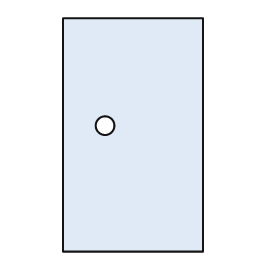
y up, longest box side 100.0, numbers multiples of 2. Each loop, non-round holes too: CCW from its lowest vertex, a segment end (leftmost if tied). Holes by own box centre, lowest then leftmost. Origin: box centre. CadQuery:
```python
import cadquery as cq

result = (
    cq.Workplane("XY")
    .moveTo(-30.0, -50.0)
    .lineTo(30.0, -50.0)
    .lineTo(30.0, 50.0)
    .lineTo(-30.0, 50.0)
    .close()
    .moveTo(-12.0, 4.0)
    .circle(4.0)
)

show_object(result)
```